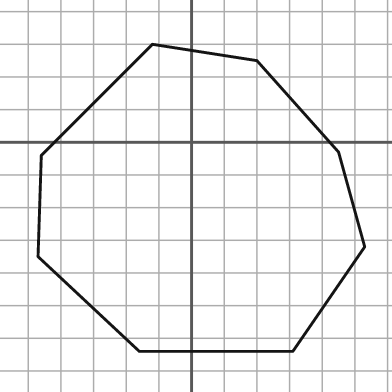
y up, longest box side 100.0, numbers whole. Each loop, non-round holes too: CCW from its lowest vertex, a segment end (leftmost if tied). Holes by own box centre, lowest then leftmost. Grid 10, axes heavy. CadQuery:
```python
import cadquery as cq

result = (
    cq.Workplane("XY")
    .moveTo(-16.0, -64.0)
    .lineTo(31.0, -64.0)
    .lineTo(53.0, -32.0)
    .lineTo(45.0, -3.0)
    .lineTo(20.0, 25.0)
    .lineTo(-12.0, 30.0)
    .lineTo(-46.0, -4.0)
    .lineTo(-47.0, -35.0)
    .close()
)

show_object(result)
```